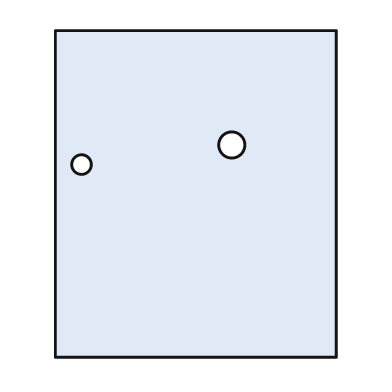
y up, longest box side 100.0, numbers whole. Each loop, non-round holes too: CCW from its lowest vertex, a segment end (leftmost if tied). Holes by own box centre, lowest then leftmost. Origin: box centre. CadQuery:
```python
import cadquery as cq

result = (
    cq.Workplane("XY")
    .moveTo(-43.0, -50.0)
    .lineTo(43.0, -50.0)
    .lineTo(43.0, 50.0)
    .lineTo(-43.0, 50.0)
    .close()
    .moveTo(-35.0, 9.0)
    .circle(3.0)
    .moveTo(11.0, 15.0)
    .circle(4.0)
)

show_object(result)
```